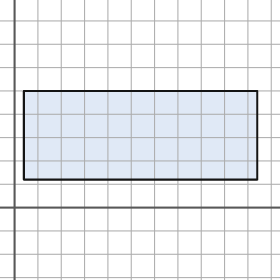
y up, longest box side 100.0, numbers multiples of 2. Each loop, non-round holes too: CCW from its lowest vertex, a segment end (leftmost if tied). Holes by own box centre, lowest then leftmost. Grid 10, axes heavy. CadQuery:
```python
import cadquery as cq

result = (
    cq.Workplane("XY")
    .moveTo(4.0, 12.0)
    .lineTo(104.0, 12.0)
    .lineTo(104.0, 50.0)
    .lineTo(4.0, 50.0)
    .close()
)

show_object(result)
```